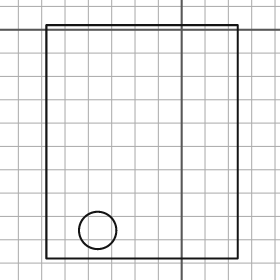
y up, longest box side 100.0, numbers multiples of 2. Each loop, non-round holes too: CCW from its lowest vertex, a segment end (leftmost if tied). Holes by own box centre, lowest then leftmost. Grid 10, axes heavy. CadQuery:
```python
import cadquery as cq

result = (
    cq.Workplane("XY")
    .moveTo(-58.0, -98.0)
    .lineTo(24.0, -98.0)
    .lineTo(24.0, 2.0)
    .lineTo(-58.0, 2.0)
    .close()
    .moveTo(-36.0, -86.0)
    .circle(8.0)
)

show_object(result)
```